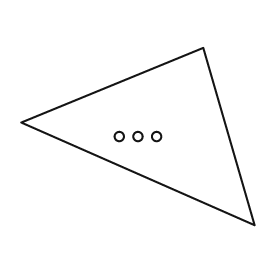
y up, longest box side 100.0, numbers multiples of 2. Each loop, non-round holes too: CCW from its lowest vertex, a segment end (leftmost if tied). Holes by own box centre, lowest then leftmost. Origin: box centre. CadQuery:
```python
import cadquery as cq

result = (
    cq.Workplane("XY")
    .moveTo(50.0, -38.0)
    .lineTo(28.0, 38.0)
    .lineTo(-50.0, 6.0)
    .close()
    .moveTo(-8.0, 0.0)
    .circle(2.0)
    .moveTo(0.0, 0.0)
    .circle(2.0)
    .moveTo(8.0, 0.0)
    .circle(2.0)
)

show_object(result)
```